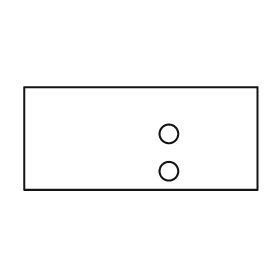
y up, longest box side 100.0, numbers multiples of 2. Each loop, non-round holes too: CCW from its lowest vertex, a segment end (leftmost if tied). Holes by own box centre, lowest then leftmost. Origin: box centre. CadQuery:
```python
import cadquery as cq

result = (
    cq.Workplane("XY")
    .moveTo(-50.0, -22.0)
    .lineTo(50.0, -22.0)
    .lineTo(50.0, 22.0)
    .lineTo(-50.0, 22.0)
    .close()
    .moveTo(12.0, -14.0)
    .circle(4.0)
    .moveTo(12.0, 2.0)
    .circle(4.0)
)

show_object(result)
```